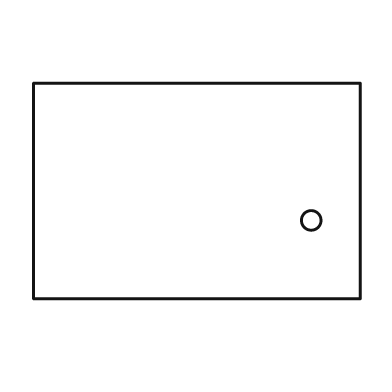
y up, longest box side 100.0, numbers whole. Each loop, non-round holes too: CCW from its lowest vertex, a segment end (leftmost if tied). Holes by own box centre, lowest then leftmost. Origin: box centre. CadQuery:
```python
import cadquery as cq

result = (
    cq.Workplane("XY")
    .moveTo(-50.0, -33.0)
    .lineTo(50.0, -33.0)
    .lineTo(50.0, 33.0)
    .lineTo(-50.0, 33.0)
    .close()
    .moveTo(35.0, -9.0)
    .circle(3.0)
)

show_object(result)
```